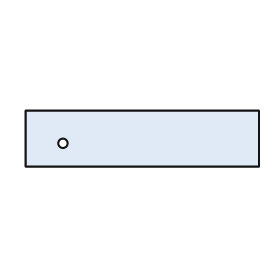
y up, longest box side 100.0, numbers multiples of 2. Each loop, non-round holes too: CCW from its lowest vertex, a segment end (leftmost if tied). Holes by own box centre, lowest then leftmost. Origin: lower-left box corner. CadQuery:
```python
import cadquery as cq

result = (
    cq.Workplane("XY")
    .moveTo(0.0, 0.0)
    .lineTo(100.0, 0.0)
    .lineTo(100.0, 24.0)
    .lineTo(0.0, 24.0)
    .close()
    .moveTo(16.0, 10.0)
    .circle(2.0)
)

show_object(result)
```